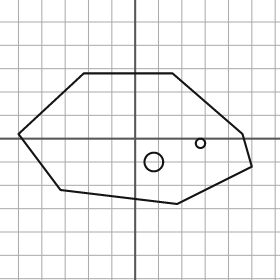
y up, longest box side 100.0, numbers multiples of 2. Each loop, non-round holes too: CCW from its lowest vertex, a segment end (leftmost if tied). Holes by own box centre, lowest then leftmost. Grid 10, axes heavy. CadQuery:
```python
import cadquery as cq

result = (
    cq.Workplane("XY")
    .moveTo(18.0, -28.0)
    .lineTo(50.0, -12.0)
    .lineTo(46.0, 2.0)
    .lineTo(16.0, 28.0)
    .lineTo(-22.0, 28.0)
    .lineTo(-50.0, 2.0)
    .lineTo(-32.0, -22.0)
    .close()
    .moveTo(8.0, -10.0)
    .circle(4.0)
    .moveTo(28.0, -2.0)
    .circle(2.0)
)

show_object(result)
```